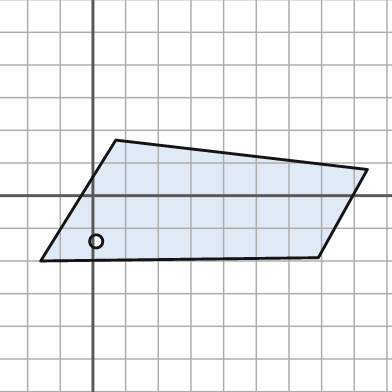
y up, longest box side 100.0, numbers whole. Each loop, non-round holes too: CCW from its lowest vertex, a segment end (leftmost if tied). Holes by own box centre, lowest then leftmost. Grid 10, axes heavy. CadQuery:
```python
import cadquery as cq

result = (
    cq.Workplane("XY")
    .moveTo(-16.0, -20.0)
    .lineTo(69.0, -19.0)
    .lineTo(84.0, 8.0)
    .lineTo(7.0, 17.0)
    .close()
    .moveTo(1.0, -14.0)
    .circle(2.0)
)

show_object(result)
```